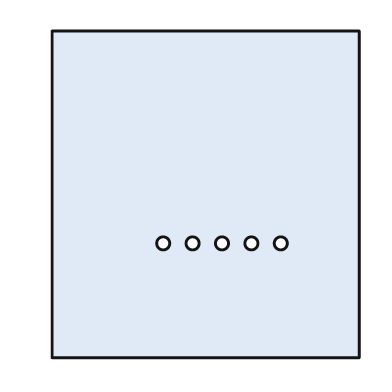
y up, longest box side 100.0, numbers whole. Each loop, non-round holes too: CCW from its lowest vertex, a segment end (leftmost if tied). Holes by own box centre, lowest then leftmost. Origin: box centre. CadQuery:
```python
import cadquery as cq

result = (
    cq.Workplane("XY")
    .moveTo(-47.0, -50.0)
    .lineTo(47.0, -50.0)
    .lineTo(47.0, 50.0)
    .lineTo(-47.0, 50.0)
    .close()
    .moveTo(-13.0, -15.0)
    .circle(2.0)
    .moveTo(-4.0, -15.0)
    .circle(2.0)
    .moveTo(5.0, -15.0)
    .circle(2.0)
    .moveTo(14.0, -15.0)
    .circle(2.0)
    .moveTo(23.0, -15.0)
    .circle(2.0)
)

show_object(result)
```